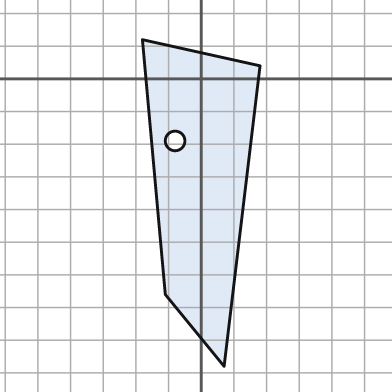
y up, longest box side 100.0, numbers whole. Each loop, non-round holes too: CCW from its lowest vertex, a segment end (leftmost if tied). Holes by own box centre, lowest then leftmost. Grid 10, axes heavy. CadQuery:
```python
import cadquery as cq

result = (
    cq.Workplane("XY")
    .moveTo(7.0, -88.0)
    .lineTo(18.0, 4.0)
    .lineTo(-18.0, 12.0)
    .lineTo(-11.0, -66.0)
    .close()
    .moveTo(-8.0, -19.0)
    .circle(3.0)
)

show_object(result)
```